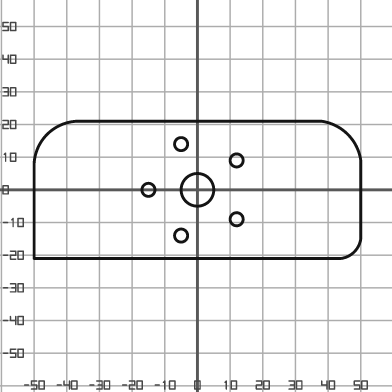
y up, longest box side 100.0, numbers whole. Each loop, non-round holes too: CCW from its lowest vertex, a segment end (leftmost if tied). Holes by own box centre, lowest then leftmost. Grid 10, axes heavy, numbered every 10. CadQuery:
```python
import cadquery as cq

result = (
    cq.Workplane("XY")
    .moveTo(-50.0, -21.0)
    .lineTo(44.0, -21.0)
    .threePointArc((48.0, -19.0), (50.0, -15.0))
    .lineTo(50.0, 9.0)
    .threePointArc((46.0, 17.0), (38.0, 21.0))
    .lineTo(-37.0, 21.0)
    .threePointArc((-46.0, 17.0), (-50.0, 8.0))
    .close()
    .moveTo(-5.0, -14.0)
    .circle(2.0)
    .moveTo(12.0, -9.0)
    .circle(2.0)
    .moveTo(-15.0, 0.0)
    .circle(2.0)
    .moveTo(0.0, 0.0)
    .circle(5.0)
    .moveTo(12.0, 9.0)
    .circle(2.0)
    .moveTo(-5.0, 14.0)
    .circle(2.0)
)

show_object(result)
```